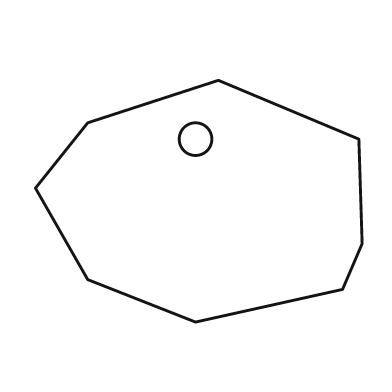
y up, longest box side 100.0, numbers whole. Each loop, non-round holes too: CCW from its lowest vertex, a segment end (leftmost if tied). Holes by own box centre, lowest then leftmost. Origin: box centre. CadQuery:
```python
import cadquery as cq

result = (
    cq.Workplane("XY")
    .moveTo(-1.0, -37.0)
    .lineTo(44.0, -27.0)
    .lineTo(50.0, -13.0)
    .lineTo(49.0, 19.0)
    .lineTo(6.0, 37.0)
    .lineTo(-34.0, 24.0)
    .lineTo(-50.0, 4.0)
    .lineTo(-34.0, -24.0)
    .close()
    .moveTo(-1.0, 19.0)
    .circle(5.0)
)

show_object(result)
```